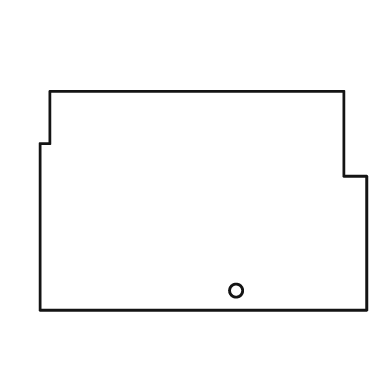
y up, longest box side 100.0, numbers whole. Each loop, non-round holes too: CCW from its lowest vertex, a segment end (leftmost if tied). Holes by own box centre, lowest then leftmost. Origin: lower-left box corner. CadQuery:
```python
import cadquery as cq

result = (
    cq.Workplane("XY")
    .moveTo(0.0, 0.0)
    .lineTo(100.0, 0.0)
    .lineTo(100.0, 41.0)
    .lineTo(93.0, 41.0)
    .lineTo(93.0, 67.0)
    .lineTo(3.0, 67.0)
    .lineTo(3.0, 51.0)
    .lineTo(0.0, 51.0)
    .close()
    .moveTo(60.0, 6.0)
    .circle(2.0)
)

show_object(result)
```